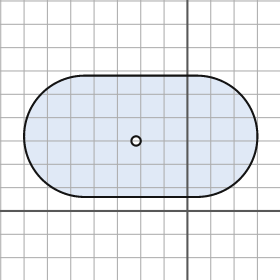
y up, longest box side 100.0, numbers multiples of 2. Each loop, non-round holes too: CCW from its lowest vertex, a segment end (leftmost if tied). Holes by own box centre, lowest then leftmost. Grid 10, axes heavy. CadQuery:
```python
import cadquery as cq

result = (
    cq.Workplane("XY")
    .moveTo(-44.0, 6.0)
    .lineTo(4.0, 6.0)
    .threePointArc((30.0, 32.0), (4.0, 58.0))
    .lineTo(-44.0, 58.0)
    .threePointArc((-70.0, 32.0), (-44.0, 6.0))
    .close()
    .moveTo(-22.0, 30.0)
    .circle(2.0)
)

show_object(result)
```